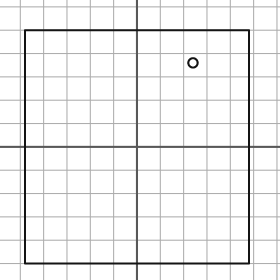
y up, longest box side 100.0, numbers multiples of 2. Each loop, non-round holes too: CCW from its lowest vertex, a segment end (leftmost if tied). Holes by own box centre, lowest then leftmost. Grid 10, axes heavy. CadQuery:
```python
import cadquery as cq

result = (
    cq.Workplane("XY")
    .moveTo(-48.0, -50.0)
    .lineTo(48.0, -50.0)
    .lineTo(48.0, 50.0)
    .lineTo(-48.0, 50.0)
    .close()
    .moveTo(24.0, 36.0)
    .circle(2.0)
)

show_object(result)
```